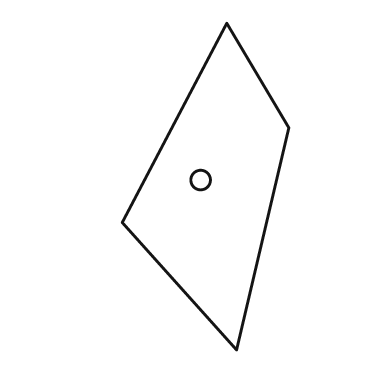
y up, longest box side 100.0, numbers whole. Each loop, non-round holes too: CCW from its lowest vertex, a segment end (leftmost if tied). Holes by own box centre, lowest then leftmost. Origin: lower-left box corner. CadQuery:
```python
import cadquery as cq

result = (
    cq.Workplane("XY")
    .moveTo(35.0, 0.0)
    .lineTo(51.0, 68.0)
    .lineTo(32.0, 100.0)
    .lineTo(0.0, 39.0)
    .close()
    .moveTo(24.0, 52.0)
    .circle(3.0)
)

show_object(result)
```